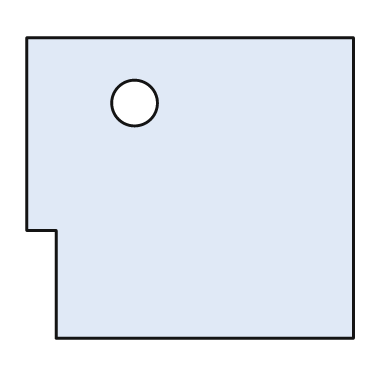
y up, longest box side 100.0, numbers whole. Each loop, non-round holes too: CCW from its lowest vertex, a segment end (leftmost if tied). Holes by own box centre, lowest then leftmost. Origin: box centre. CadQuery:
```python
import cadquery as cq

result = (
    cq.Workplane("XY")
    .moveTo(-41.0, -46.0)
    .lineTo(50.0, -46.0)
    .lineTo(50.0, 46.0)
    .lineTo(-50.0, 46.0)
    .lineTo(-50.0, -13.0)
    .lineTo(-41.0, -13.0)
    .close()
    .moveTo(-17.0, 26.0)
    .circle(7.0)
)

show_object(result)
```